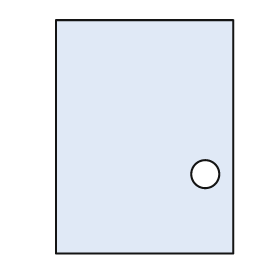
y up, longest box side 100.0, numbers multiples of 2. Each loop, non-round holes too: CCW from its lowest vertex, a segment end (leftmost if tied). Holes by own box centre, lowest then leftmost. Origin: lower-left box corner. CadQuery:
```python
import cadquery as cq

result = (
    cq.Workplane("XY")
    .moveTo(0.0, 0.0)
    .lineTo(76.0, 0.0)
    .lineTo(76.0, 100.0)
    .lineTo(0.0, 100.0)
    .close()
    .moveTo(64.0, 34.0)
    .circle(6.0)
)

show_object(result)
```